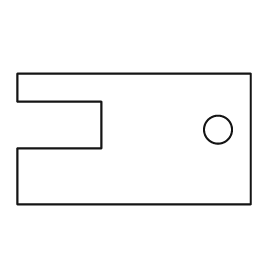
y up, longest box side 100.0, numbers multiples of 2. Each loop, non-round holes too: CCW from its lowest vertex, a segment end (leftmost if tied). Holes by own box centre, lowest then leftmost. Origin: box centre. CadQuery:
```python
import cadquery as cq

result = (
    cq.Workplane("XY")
    .moveTo(-50.0, -28.0)
    .lineTo(50.0, -28.0)
    .lineTo(50.0, 28.0)
    .lineTo(-50.0, 28.0)
    .lineTo(-50.0, 16.0)
    .lineTo(-14.0, 16.0)
    .lineTo(-14.0, -4.0)
    .lineTo(-50.0, -4.0)
    .close()
    .moveTo(36.0, 4.0)
    .circle(6.0)
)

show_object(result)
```